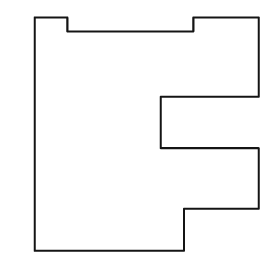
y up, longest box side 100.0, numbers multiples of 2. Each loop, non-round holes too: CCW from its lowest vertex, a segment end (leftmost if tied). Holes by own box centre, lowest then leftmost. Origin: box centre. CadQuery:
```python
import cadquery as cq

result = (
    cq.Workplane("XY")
    .moveTo(-48.0, -50.0)
    .lineTo(16.0, -50.0)
    .lineTo(16.0, -32.0)
    .lineTo(48.0, -32.0)
    .lineTo(48.0, -6.0)
    .lineTo(6.0, -6.0)
    .lineTo(6.0, 16.0)
    .lineTo(48.0, 16.0)
    .lineTo(48.0, 50.0)
    .lineTo(20.0, 50.0)
    .lineTo(20.0, 44.0)
    .lineTo(-34.0, 44.0)
    .lineTo(-34.0, 50.0)
    .lineTo(-48.0, 50.0)
    .close()
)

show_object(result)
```